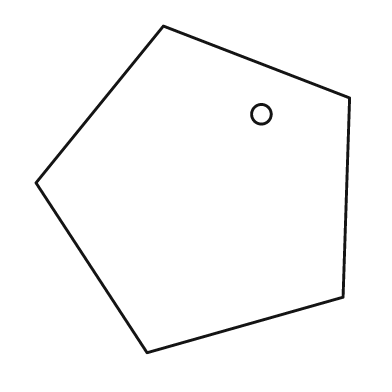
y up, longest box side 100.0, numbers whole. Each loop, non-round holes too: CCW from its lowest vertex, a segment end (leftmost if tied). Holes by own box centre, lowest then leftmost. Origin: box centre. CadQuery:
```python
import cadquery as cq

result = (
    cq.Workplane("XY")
    .moveTo(-14.0, -50.0)
    .lineTo(46.0, -33.0)
    .lineTo(48.0, 28.0)
    .lineTo(-9.0, 50.0)
    .lineTo(-48.0, 2.0)
    .close()
    .moveTo(21.0, 23.0)
    .circle(3.0)
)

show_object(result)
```